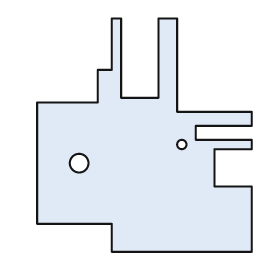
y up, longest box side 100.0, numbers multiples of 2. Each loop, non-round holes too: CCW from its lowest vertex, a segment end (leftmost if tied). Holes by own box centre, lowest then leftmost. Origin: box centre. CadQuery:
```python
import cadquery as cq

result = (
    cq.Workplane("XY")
    .moveTo(-14.0, -50.0)
    .lineTo(46.0, -50.0)
    .lineTo(46.0, -22.0)
    .lineTo(30.0, -22.0)
    .lineTo(30.0, -6.0)
    .lineTo(46.0, -6.0)
    .lineTo(46.0, -2.0)
    .lineTo(22.0, -2.0)
    .lineTo(22.0, 4.0)
    .lineTo(46.0, 4.0)
    .lineTo(46.0, 10.0)
    .lineTo(14.0, 10.0)
    .lineTo(14.0, 50.0)
    .lineTo(6.0, 50.0)
    .lineTo(6.0, 16.0)
    .lineTo(-10.0, 16.0)
    .lineTo(-10.0, 50.0)
    .lineTo(-14.0, 50.0)
    .lineTo(-14.0, 28.0)
    .lineTo(-20.0, 28.0)
    .lineTo(-20.0, 14.0)
    .lineTo(-46.0, 14.0)
    .lineTo(-46.0, -38.0)
    .lineTo(-14.0, -38.0)
    .close()
    .moveTo(-28.0, -12.0)
    .circle(4.0)
    .moveTo(16.0, -4.0)
    .circle(2.0)
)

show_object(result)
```